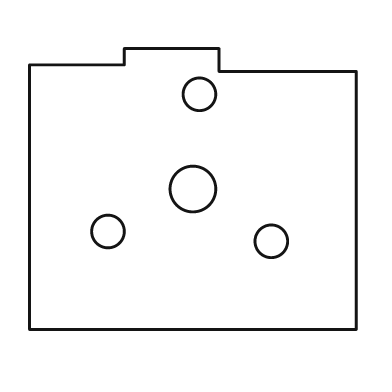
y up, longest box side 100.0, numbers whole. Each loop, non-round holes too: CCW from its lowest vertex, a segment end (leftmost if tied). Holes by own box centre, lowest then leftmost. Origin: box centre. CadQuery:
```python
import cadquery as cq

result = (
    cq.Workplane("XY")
    .moveTo(-50.0, -43.0)
    .lineTo(50.0, -43.0)
    .lineTo(50.0, 36.0)
    .lineTo(8.0, 36.0)
    .lineTo(8.0, 43.0)
    .lineTo(-21.0, 43.0)
    .lineTo(-21.0, 38.0)
    .lineTo(-50.0, 38.0)
    .close()
    .moveTo(24.0, -16.0)
    .circle(5.0)
    .moveTo(-26.0, -13.0)
    .circle(5.0)
    .moveTo(0.0, 0.0)
    .circle(7.0)
    .moveTo(2.0, 29.0)
    .circle(5.0)
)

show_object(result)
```